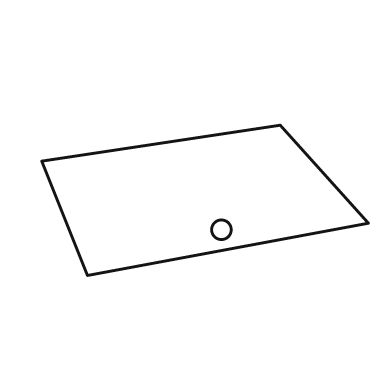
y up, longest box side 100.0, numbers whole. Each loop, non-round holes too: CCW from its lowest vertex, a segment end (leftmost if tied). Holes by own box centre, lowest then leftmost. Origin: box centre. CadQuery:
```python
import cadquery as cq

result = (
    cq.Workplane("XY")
    .moveTo(-36.0, -23.0)
    .lineTo(50.0, -7.0)
    .lineTo(23.0, 23.0)
    .lineTo(-50.0, 12.0)
    .close()
    .moveTo(5.0, -9.0)
    .circle(3.0)
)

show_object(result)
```